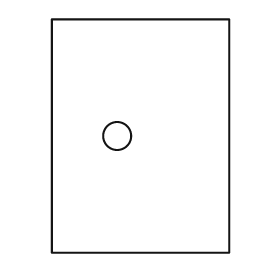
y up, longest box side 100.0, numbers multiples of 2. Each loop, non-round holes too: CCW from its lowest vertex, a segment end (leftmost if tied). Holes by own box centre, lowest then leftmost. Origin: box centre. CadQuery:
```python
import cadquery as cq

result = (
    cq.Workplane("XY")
    .moveTo(-38.0, -50.0)
    .lineTo(38.0, -50.0)
    .lineTo(38.0, 50.0)
    .lineTo(-38.0, 50.0)
    .close()
    .moveTo(-10.0, 0.0)
    .circle(6.0)
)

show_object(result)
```